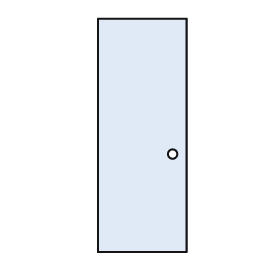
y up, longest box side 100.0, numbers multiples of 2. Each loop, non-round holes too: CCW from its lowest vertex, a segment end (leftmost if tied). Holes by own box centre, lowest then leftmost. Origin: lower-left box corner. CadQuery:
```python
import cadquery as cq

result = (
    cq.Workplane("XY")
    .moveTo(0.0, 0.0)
    .lineTo(38.0, 0.0)
    .lineTo(38.0, 100.0)
    .lineTo(0.0, 100.0)
    .close()
    .moveTo(32.0, 42.0)
    .circle(2.0)
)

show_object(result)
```